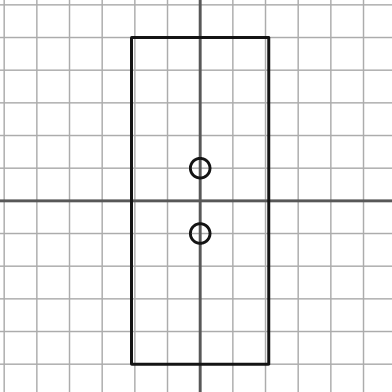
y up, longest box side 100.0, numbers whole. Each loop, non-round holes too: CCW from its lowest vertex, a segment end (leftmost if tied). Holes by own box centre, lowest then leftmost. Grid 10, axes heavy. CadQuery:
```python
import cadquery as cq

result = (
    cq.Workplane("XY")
    .moveTo(-21.0, -50.0)
    .lineTo(21.0, -50.0)
    .lineTo(21.0, 50.0)
    .lineTo(-21.0, 50.0)
    .close()
    .moveTo(0.0, -10.0)
    .circle(3.0)
    .moveTo(0.0, 10.0)
    .circle(3.0)
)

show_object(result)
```